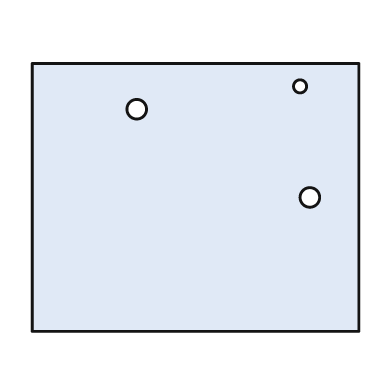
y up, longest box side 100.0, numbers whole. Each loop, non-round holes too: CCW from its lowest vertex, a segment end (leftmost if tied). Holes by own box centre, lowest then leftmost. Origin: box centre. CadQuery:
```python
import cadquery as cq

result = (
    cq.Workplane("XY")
    .moveTo(-50.0, -41.0)
    .lineTo(50.0, -41.0)
    .lineTo(50.0, 41.0)
    .lineTo(-50.0, 41.0)
    .close()
    .moveTo(35.0, 0.0)
    .circle(3.0)
    .moveTo(-18.0, 27.0)
    .circle(3.0)
    .moveTo(32.0, 34.0)
    .circle(2.0)
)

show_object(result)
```